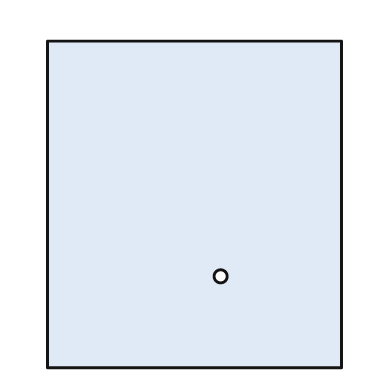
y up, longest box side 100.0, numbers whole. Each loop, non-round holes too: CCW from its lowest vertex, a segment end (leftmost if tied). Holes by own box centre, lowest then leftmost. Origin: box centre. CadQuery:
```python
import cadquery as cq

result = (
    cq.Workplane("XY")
    .moveTo(-45.0, -50.0)
    .lineTo(45.0, -50.0)
    .lineTo(45.0, 50.0)
    .lineTo(-45.0, 50.0)
    .close()
    .moveTo(8.0, -22.0)
    .circle(2.0)
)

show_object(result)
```